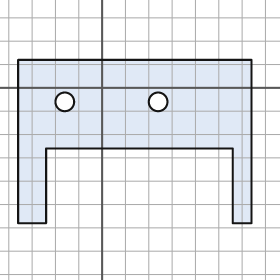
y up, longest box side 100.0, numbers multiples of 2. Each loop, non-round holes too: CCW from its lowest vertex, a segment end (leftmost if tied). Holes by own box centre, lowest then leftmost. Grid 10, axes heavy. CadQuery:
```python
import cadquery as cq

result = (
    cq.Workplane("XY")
    .moveTo(-36.0, -58.0)
    .lineTo(-24.0, -58.0)
    .lineTo(-24.0, -26.0)
    .lineTo(56.0, -26.0)
    .lineTo(56.0, -58.0)
    .lineTo(64.0, -58.0)
    .lineTo(64.0, 12.0)
    .lineTo(-36.0, 12.0)
    .close()
    .moveTo(-16.0, -6.0)
    .circle(4.0)
    .moveTo(24.0, -6.0)
    .circle(4.0)
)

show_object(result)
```